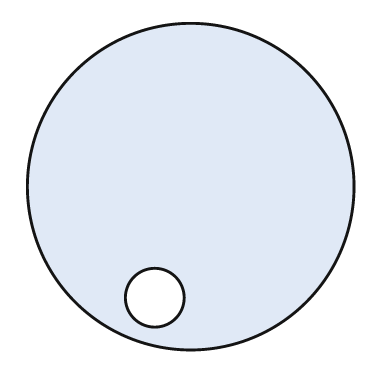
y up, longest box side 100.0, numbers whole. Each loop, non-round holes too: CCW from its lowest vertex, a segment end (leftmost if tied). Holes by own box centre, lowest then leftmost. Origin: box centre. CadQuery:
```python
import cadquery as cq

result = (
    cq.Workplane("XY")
    .moveTo(0.0, 0.0)
    .circle(50.0)
    .moveTo(-11.0, -34.0)
    .circle(9.0)
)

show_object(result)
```